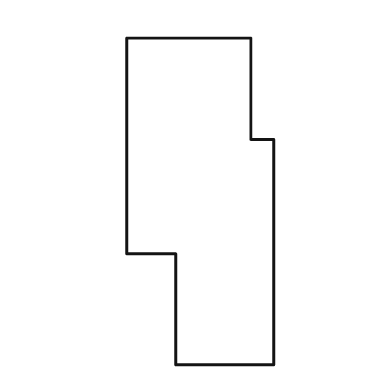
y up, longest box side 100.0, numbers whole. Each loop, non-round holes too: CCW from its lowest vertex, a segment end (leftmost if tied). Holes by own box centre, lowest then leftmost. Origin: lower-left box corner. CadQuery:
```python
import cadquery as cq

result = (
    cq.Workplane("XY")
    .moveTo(15.0, 0.0)
    .lineTo(45.0, 0.0)
    .lineTo(45.0, 69.0)
    .lineTo(38.0, 69.0)
    .lineTo(38.0, 100.0)
    .lineTo(0.0, 100.0)
    .lineTo(0.0, 34.0)
    .lineTo(15.0, 34.0)
    .close()
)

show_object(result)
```